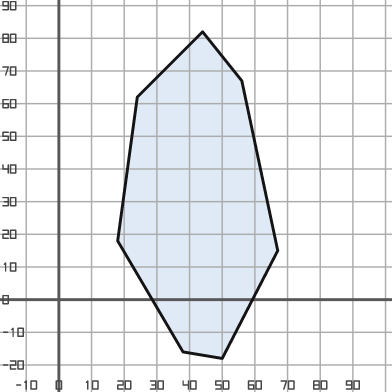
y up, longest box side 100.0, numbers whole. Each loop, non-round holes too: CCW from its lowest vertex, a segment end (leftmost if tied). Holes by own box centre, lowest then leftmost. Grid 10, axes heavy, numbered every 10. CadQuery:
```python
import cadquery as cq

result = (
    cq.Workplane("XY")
    .moveTo(50.0, -18.0)
    .lineTo(67.0, 15.0)
    .lineTo(56.0, 67.0)
    .lineTo(44.0, 82.0)
    .lineTo(24.0, 62.0)
    .lineTo(18.0, 18.0)
    .lineTo(38.0, -16.0)
    .close()
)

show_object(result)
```